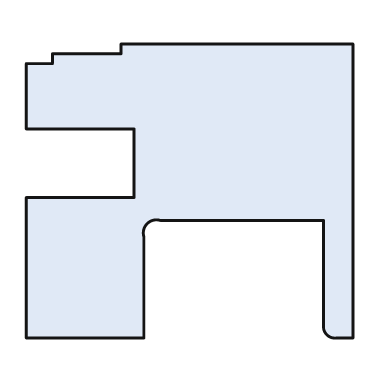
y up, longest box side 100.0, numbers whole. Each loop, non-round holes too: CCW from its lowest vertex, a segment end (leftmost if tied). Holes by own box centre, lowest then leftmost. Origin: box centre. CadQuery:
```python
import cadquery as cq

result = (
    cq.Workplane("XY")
    .moveTo(-50.0, -45.0)
    .lineTo(-14.0, -45.0)
    .lineTo(-14.0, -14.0)
    .threePointArc((-13.0, -10.0), (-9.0, -9.0))
    .lineTo(41.0, -9.0)
    .lineTo(41.0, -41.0)
    .threePointArc((42.0, -44.0), (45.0, -45.0))
    .lineTo(50.0, -45.0)
    .lineTo(50.0, 45.0)
    .lineTo(-21.0, 45.0)
    .lineTo(-21.0, 42.0)
    .lineTo(-42.0, 42.0)
    .lineTo(-42.0, 39.0)
    .lineTo(-50.0, 39.0)
    .lineTo(-50.0, 19.0)
    .lineTo(-17.0, 19.0)
    .lineTo(-17.0, -2.0)
    .lineTo(-50.0, -2.0)
    .close()
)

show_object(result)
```